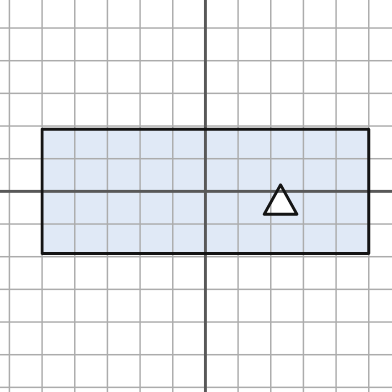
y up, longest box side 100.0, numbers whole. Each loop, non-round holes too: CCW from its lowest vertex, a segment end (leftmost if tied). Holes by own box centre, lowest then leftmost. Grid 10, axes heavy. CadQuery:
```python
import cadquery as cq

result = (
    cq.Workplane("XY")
    .moveTo(-50.0, -19.0)
    .lineTo(50.0, -19.0)
    .lineTo(50.0, 19.0)
    .lineTo(-50.0, 19.0)
    .close()
    .moveTo(18.0, -7.0)
    .lineTo(28.0, -7.0)
    .lineTo(23.0, 2.0)
    .close()
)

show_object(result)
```